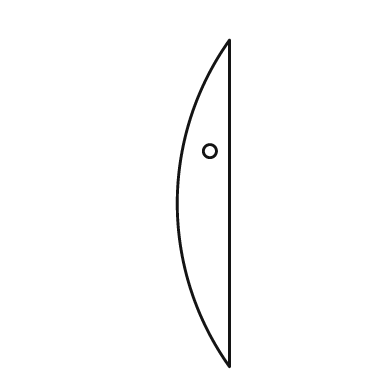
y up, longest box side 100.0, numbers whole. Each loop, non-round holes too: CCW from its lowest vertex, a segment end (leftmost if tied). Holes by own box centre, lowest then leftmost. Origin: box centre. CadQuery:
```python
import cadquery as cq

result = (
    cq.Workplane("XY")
    .moveTo(8.0, -50.0)
    .lineTo(8.0, 50.0)
    .threePointArc((-8.0, 0.0), (8.0, -50.0))
    .close()
    .moveTo(2.0, 16.0)
    .circle(2.0)
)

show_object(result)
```